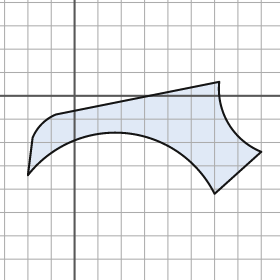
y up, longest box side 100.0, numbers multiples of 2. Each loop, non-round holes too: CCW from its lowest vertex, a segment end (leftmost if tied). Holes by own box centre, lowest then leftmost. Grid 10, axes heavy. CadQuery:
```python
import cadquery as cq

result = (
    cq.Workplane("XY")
    .moveTo(60.0, -42.0)
    .lineTo(80.0, -24.0)
    .threePointArc((66.0, -12.0), (62.0, 6.0))
    .lineTo(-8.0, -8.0)
    .threePointArc((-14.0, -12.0), (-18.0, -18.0))
    .lineTo(-20.0, -34.0)
    .threePointArc((22.0, -16.0), (60.0, -42.0))
    .close()
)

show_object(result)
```